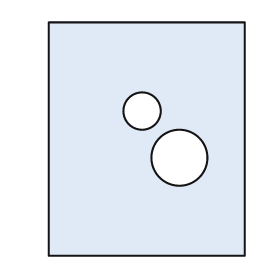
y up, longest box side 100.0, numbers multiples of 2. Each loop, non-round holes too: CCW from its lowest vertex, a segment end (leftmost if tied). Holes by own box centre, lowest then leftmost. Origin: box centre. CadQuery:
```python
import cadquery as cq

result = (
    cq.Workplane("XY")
    .moveTo(-42.0, -50.0)
    .lineTo(42.0, -50.0)
    .lineTo(42.0, 50.0)
    .lineTo(-42.0, 50.0)
    .close()
    .moveTo(14.0, -8.0)
    .circle(12.0)
    .moveTo(-2.0, 12.0)
    .circle(8.0)
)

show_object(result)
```